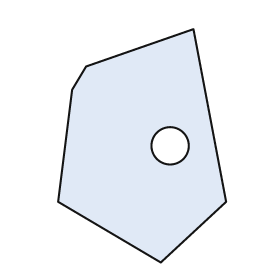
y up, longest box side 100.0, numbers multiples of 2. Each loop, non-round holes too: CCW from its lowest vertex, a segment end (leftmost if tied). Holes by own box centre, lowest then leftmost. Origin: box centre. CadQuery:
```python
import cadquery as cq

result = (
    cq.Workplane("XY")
    .moveTo(8.0, -50.0)
    .lineTo(36.0, -24.0)
    .lineTo(22.0, 50.0)
    .lineTo(-24.0, 34.0)
    .lineTo(-30.0, 24.0)
    .lineTo(-36.0, -24.0)
    .close()
    .moveTo(12.0, 0.0)
    .circle(8.0)
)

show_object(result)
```